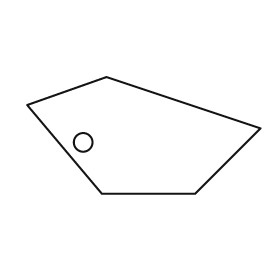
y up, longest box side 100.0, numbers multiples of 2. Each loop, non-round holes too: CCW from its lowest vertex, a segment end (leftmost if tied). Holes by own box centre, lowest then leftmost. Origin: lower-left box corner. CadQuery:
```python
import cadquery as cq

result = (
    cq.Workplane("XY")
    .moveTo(32.0, 0.0)
    .lineTo(72.0, 0.0)
    .lineTo(100.0, 28.0)
    .lineTo(34.0, 50.0)
    .lineTo(0.0, 38.0)
    .close()
    .moveTo(24.0, 22.0)
    .circle(4.0)
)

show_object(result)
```